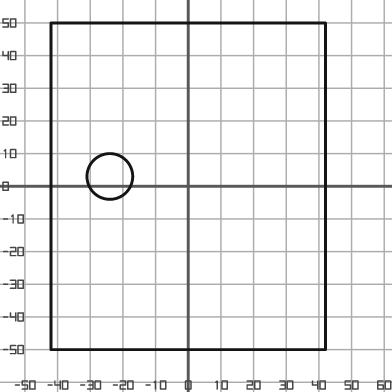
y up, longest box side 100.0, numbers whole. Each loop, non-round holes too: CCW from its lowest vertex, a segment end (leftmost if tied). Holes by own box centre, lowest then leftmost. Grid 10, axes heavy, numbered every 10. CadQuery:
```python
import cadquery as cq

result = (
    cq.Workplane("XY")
    .moveTo(-42.0, -50.0)
    .lineTo(42.0, -50.0)
    .lineTo(42.0, 50.0)
    .lineTo(-42.0, 50.0)
    .close()
    .moveTo(-24.0, 3.0)
    .circle(7.0)
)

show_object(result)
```